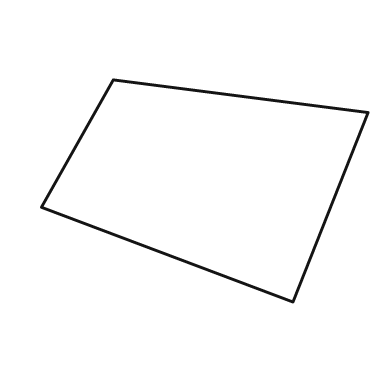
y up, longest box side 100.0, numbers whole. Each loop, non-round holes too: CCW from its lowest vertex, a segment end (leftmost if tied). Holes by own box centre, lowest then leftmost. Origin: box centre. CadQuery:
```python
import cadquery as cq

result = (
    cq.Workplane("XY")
    .moveTo(27.0, -34.0)
    .lineTo(50.0, 24.0)
    .lineTo(-28.0, 34.0)
    .lineTo(-50.0, -5.0)
    .close()
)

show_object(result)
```